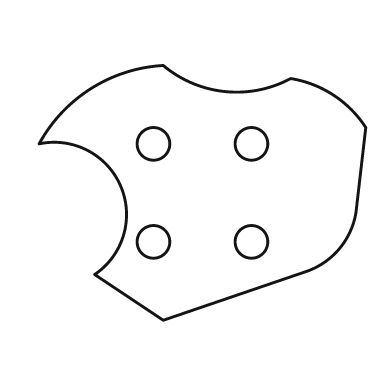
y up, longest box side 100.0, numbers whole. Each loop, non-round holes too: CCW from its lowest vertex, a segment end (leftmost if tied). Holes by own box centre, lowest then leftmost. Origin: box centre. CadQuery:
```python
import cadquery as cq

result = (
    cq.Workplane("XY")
    .moveTo(-12.0, -39.0)
    .lineTo(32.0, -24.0)
    .threePointArc((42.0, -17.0), (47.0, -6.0))
    .lineTo(50.0, 20.0)
    .threePointArc((40.0, 30.0), (27.0, 35.0))
    .threePointArc((7.0, 31.0), (-12.0, 39.0))
    .threePointArc((-34.0, 32.0), (-50.0, 15.0))
    .threePointArc((-25.0, 2.0), (-33.0, -25.0))
    .close()
    .moveTo(-15.0, -15.0)
    .circle(5.0)
    .moveTo(15.0, -15.0)
    .circle(5.0)
    .moveTo(-15.0, 15.0)
    .circle(5.0)
    .moveTo(15.0, 15.0)
    .circle(5.0)
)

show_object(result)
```